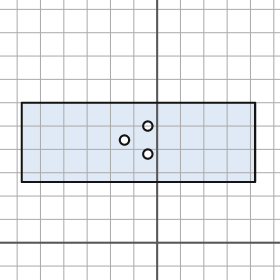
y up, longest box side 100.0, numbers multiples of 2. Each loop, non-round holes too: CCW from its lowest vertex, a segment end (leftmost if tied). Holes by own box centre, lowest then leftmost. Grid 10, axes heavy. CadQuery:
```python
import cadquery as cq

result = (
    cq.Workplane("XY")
    .moveTo(-58.0, 26.0)
    .lineTo(42.0, 26.0)
    .lineTo(42.0, 60.0)
    .lineTo(-58.0, 60.0)
    .close()
    .moveTo(-4.0, 38.0)
    .circle(2.0)
    .moveTo(-14.0, 44.0)
    .circle(2.0)
    .moveTo(-4.0, 50.0)
    .circle(2.0)
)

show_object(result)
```